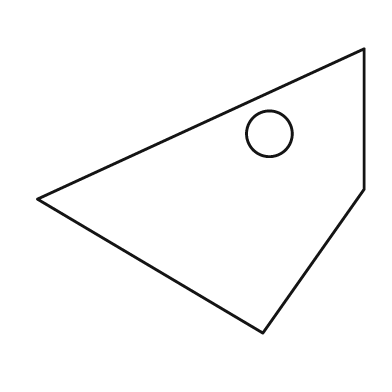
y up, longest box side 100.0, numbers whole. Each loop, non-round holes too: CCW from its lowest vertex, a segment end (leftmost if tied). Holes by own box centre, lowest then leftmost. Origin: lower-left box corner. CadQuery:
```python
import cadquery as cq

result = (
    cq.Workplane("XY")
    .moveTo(69.0, 0.0)
    .lineTo(100.0, 44.0)
    .lineTo(100.0, 87.0)
    .lineTo(0.0, 41.0)
    .close()
    .moveTo(71.0, 61.0)
    .circle(7.0)
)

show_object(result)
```